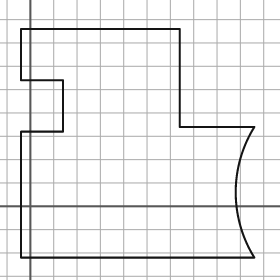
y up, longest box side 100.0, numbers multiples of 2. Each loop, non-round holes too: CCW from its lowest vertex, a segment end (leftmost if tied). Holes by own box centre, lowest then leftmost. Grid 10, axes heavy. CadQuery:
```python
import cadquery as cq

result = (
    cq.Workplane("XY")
    .moveTo(-4.0, -22.0)
    .lineTo(96.0, -22.0)
    .threePointArc((88.0, 6.0), (96.0, 34.0))
    .lineTo(64.0, 34.0)
    .lineTo(64.0, 76.0)
    .lineTo(-4.0, 76.0)
    .lineTo(-4.0, 54.0)
    .lineTo(14.0, 54.0)
    .lineTo(14.0, 32.0)
    .lineTo(-4.0, 32.0)
    .close()
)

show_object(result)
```